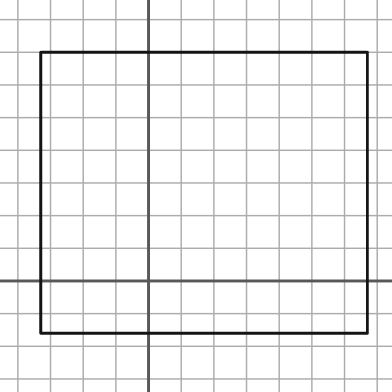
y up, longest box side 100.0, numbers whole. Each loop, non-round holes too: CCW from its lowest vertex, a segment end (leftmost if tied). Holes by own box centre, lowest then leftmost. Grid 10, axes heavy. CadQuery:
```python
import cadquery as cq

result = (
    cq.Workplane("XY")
    .moveTo(-33.0, -16.0)
    .lineTo(67.0, -16.0)
    .lineTo(67.0, 70.0)
    .lineTo(-33.0, 70.0)
    .close()
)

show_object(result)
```